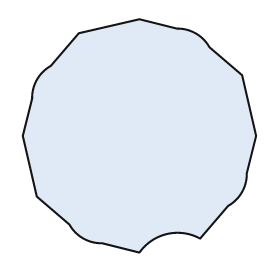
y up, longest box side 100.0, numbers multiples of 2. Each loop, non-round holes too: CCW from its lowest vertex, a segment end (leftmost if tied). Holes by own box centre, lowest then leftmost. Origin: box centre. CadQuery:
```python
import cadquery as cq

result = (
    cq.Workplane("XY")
    .moveTo(0.0, -50.0)
    .threePointArc((12.0, -42.0), (26.0, -44.0))
    .lineTo(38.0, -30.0)
    .threePointArc((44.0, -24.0), (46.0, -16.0))
    .lineTo(50.0, 0.0)
    .lineTo(44.0, 26.0)
    .lineTo(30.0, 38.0)
    .threePointArc((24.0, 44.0), (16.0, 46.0))
    .lineTo(0.0, 50.0)
    .lineTo(-26.0, 44.0)
    .lineTo(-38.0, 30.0)
    .threePointArc((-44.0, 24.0), (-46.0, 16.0))
    .lineTo(-50.0, 0.0)
    .lineTo(-44.0, -26.0)
    .lineTo(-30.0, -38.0)
    .threePointArc((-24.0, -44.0), (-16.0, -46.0))
    .close()
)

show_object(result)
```